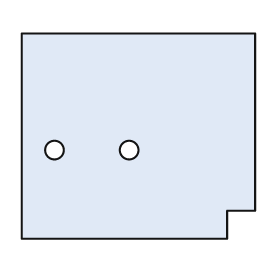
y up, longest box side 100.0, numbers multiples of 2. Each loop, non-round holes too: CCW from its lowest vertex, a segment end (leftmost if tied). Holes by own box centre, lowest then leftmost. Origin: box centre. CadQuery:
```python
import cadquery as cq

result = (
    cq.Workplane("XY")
    .moveTo(-50.0, -44.0)
    .lineTo(38.0, -44.0)
    .lineTo(38.0, -32.0)
    .lineTo(50.0, -32.0)
    .lineTo(50.0, 44.0)
    .lineTo(-50.0, 44.0)
    .close()
    .moveTo(-36.0, -6.0)
    .circle(4.0)
    .moveTo(-4.0, -6.0)
    .circle(4.0)
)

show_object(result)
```